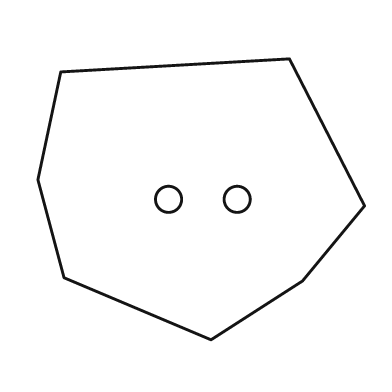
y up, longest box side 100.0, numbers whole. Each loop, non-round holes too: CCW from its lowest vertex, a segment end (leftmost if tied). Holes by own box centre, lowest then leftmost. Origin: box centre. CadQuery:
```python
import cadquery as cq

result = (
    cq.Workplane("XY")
    .moveTo(3.0, -43.0)
    .lineTo(31.0, -25.0)
    .lineTo(50.0, -2.0)
    .lineTo(27.0, 43.0)
    .lineTo(-43.0, 39.0)
    .lineTo(-50.0, 6.0)
    .lineTo(-42.0, -24.0)
    .close()
    .moveTo(-10.0, 0.0)
    .circle(4.0)
    .moveTo(11.0, 0.0)
    .circle(4.0)
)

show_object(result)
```